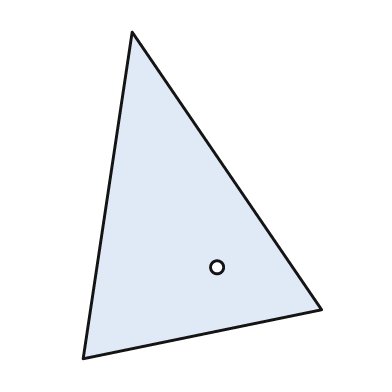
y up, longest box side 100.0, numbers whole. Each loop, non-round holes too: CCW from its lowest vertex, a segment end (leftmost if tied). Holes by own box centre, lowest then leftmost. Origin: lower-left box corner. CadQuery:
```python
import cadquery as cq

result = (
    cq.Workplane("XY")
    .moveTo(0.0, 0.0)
    .lineTo(73.0, 15.0)
    .lineTo(15.0, 100.0)
    .close()
    .moveTo(41.0, 28.0)
    .circle(2.0)
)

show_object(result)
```